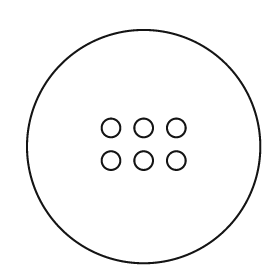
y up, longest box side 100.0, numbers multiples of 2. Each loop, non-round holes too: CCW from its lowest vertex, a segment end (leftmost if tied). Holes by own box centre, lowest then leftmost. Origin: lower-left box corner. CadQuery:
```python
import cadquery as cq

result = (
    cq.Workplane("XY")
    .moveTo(50.0, 50.0)
    .circle(50.0)
    .moveTo(36.0, 44.0)
    .circle(4.0)
    .moveTo(50.0, 44.0)
    .circle(4.0)
    .moveTo(64.0, 44.0)
    .circle(4.0)
    .moveTo(36.0, 58.0)
    .circle(4.0)
    .moveTo(50.0, 58.0)
    .circle(4.0)
    .moveTo(64.0, 58.0)
    .circle(4.0)
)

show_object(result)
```